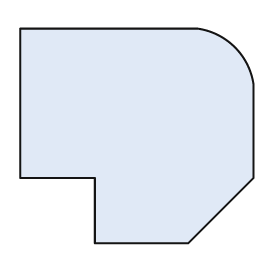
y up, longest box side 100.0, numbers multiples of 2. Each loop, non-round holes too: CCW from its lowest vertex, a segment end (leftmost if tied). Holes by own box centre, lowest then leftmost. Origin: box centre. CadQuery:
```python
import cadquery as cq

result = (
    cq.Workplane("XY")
    .moveTo(-18.0, -46.0)
    .lineTo(22.0, -46.0)
    .lineTo(50.0, -18.0)
    .lineTo(50.0, 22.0)
    .threePointArc((42.0, 38.0), (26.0, 46.0))
    .lineTo(-50.0, 46.0)
    .lineTo(-50.0, -18.0)
    .lineTo(-18.0, -18.0)
    .close()
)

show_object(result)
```